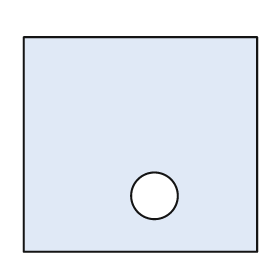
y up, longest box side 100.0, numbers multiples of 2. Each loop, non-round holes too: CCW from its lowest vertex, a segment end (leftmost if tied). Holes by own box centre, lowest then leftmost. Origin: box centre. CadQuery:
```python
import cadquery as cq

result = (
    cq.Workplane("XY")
    .moveTo(-50.0, -46.0)
    .lineTo(50.0, -46.0)
    .lineTo(50.0, 46.0)
    .lineTo(-50.0, 46.0)
    .close()
    .moveTo(6.0, -22.0)
    .circle(10.0)
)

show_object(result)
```